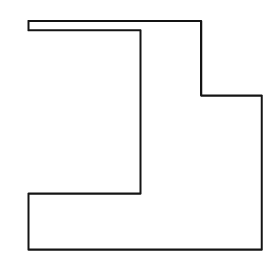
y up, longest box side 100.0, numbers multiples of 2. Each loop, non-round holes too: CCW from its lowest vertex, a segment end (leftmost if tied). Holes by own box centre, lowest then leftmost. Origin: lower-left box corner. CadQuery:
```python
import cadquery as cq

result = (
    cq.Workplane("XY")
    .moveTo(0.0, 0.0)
    .lineTo(100.0, 0.0)
    .lineTo(100.0, 66.0)
    .lineTo(74.0, 66.0)
    .lineTo(74.0, 98.0)
    .lineTo(0.0, 98.0)
    .lineTo(0.0, 94.0)
    .lineTo(48.0, 94.0)
    .lineTo(48.0, 24.0)
    .lineTo(0.0, 24.0)
    .close()
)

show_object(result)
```